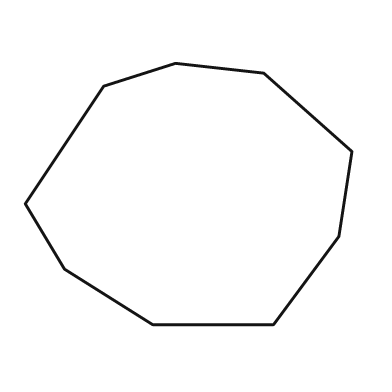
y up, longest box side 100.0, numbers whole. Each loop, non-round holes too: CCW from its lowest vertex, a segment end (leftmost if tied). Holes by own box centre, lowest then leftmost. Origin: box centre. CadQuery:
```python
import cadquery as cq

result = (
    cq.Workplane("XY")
    .moveTo(-11.0, -40.0)
    .lineTo(26.0, -40.0)
    .lineTo(46.0, -13.0)
    .lineTo(50.0, 13.0)
    .lineTo(23.0, 37.0)
    .lineTo(-4.0, 40.0)
    .lineTo(-26.0, 33.0)
    .lineTo(-50.0, -3.0)
    .lineTo(-38.0, -23.0)
    .close()
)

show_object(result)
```